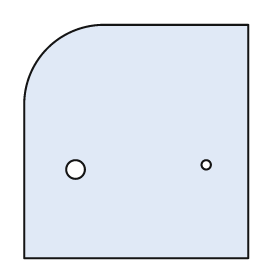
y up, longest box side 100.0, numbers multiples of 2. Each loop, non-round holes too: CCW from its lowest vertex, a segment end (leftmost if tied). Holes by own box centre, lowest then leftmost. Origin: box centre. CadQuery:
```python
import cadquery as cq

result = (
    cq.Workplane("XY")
    .moveTo(-48.0, -50.0)
    .lineTo(48.0, -50.0)
    .lineTo(48.0, 50.0)
    .lineTo(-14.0, 50.0)
    .threePointArc((-38.0, 40.0), (-48.0, 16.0))
    .close()
    .moveTo(-26.0, -12.0)
    .circle(4.0)
    .moveTo(30.0, -10.0)
    .circle(2.0)
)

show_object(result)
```